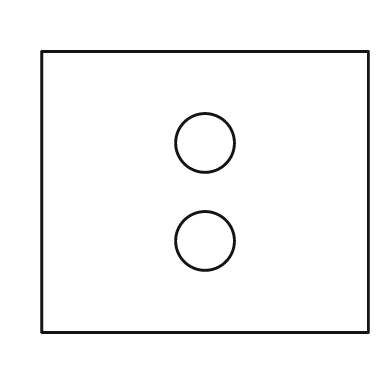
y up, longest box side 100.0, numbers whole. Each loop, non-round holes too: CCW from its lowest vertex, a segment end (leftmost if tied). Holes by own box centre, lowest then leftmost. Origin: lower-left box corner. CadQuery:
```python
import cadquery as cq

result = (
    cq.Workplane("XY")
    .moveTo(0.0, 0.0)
    .lineTo(100.0, 0.0)
    .lineTo(100.0, 86.0)
    .lineTo(0.0, 86.0)
    .close()
    .moveTo(50.0, 28.0)
    .circle(9.0)
    .moveTo(50.0, 58.0)
    .circle(9.0)
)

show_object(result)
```